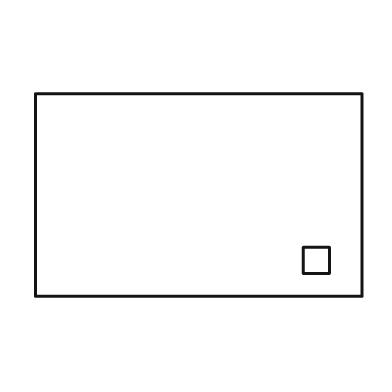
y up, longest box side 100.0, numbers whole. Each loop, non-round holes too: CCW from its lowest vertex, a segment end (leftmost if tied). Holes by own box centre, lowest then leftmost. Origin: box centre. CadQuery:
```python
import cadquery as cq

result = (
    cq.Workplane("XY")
    .moveTo(-50.0, -31.0)
    .lineTo(50.0, -31.0)
    .lineTo(50.0, 31.0)
    .lineTo(-50.0, 31.0)
    .close()
    .moveTo(32.0, -24.0)
    .lineTo(40.0, -24.0)
    .lineTo(40.0, -16.0)
    .lineTo(32.0, -16.0)
    .close()
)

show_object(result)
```